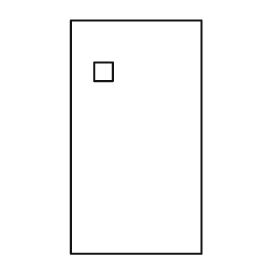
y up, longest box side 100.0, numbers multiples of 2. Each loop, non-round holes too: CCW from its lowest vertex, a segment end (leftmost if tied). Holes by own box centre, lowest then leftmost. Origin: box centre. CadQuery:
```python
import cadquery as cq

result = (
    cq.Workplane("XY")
    .moveTo(-28.0, -50.0)
    .lineTo(28.0, -50.0)
    .lineTo(28.0, 50.0)
    .lineTo(-28.0, 50.0)
    .close()
    .moveTo(-18.0, 24.0)
    .lineTo(-10.0, 24.0)
    .lineTo(-10.0, 32.0)
    .lineTo(-18.0, 32.0)
    .close()
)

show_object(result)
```